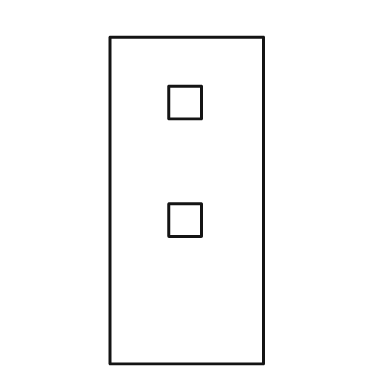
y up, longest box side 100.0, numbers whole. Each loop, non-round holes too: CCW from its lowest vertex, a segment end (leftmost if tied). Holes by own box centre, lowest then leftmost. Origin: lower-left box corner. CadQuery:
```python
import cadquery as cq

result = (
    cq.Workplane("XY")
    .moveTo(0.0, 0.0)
    .lineTo(47.0, 0.0)
    .lineTo(47.0, 100.0)
    .lineTo(0.0, 100.0)
    .close()
    .moveTo(18.0, 39.0)
    .lineTo(28.0, 39.0)
    .lineTo(28.0, 49.0)
    .lineTo(18.0, 49.0)
    .close()
    .moveTo(18.0, 75.0)
    .lineTo(28.0, 75.0)
    .lineTo(28.0, 85.0)
    .lineTo(18.0, 85.0)
    .close()
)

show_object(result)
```